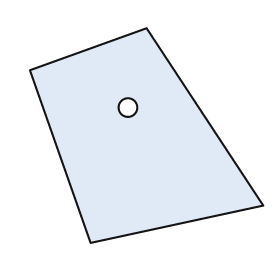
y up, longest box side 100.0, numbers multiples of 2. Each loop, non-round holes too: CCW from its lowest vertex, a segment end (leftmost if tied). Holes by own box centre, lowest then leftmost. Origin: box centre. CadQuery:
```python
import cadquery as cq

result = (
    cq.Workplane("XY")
    .moveTo(-24.0, -46.0)
    .lineTo(50.0, -30.0)
    .lineTo(0.0, 46.0)
    .lineTo(-50.0, 28.0)
    .close()
    .moveTo(-8.0, 12.0)
    .circle(4.0)
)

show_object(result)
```